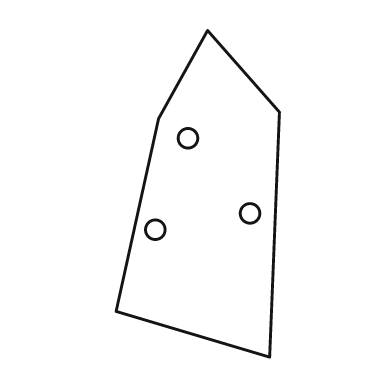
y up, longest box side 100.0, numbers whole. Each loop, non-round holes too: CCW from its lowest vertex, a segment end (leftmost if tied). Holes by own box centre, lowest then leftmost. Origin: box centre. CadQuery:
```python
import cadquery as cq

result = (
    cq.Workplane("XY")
    .moveTo(22.0, -50.0)
    .lineTo(25.0, 25.0)
    .lineTo(3.0, 50.0)
    .lineTo(-12.0, 23.0)
    .lineTo(-25.0, -36.0)
    .close()
    .moveTo(-13.0, -11.0)
    .circle(3.0)
    .moveTo(16.0, -6.0)
    .circle(3.0)
    .moveTo(-3.0, 17.0)
    .circle(3.0)
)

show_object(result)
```